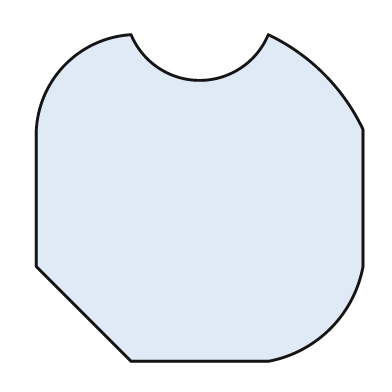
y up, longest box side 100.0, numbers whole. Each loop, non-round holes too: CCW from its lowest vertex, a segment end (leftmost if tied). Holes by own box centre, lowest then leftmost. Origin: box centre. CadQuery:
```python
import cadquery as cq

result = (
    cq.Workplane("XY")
    .moveTo(-21.0, -50.0)
    .lineTo(21.0, -50.0)
    .threePointArc((40.0, -40.0), (50.0, -21.0))
    .lineTo(50.0, 21.0)
    .threePointArc((38.0, 38.0), (21.0, 50.0))
    .threePointArc((0.0, 36.0), (-21.0, 50.0))
    .threePointArc((-41.0, 41.0), (-50.0, 21.0))
    .lineTo(-50.0, -21.0)
    .close()
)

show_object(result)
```